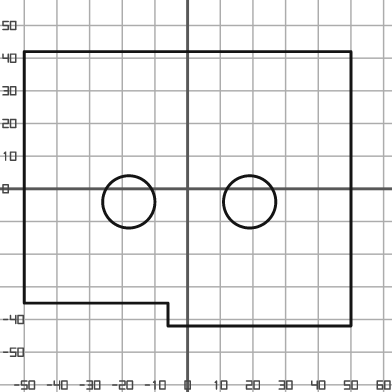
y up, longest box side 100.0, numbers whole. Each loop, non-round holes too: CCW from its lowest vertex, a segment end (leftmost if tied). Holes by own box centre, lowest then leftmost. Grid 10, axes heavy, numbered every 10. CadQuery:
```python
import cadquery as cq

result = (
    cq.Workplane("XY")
    .moveTo(-6.0, -42.0)
    .lineTo(50.0, -42.0)
    .lineTo(50.0, 42.0)
    .lineTo(-50.0, 42.0)
    .lineTo(-50.0, -35.0)
    .lineTo(-6.0, -35.0)
    .close()
    .moveTo(-18.0, -4.0)
    .circle(8.0)
    .moveTo(19.0, -4.0)
    .circle(8.0)
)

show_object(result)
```